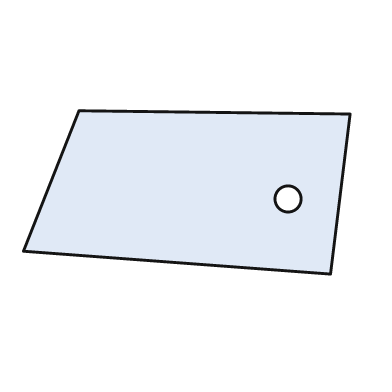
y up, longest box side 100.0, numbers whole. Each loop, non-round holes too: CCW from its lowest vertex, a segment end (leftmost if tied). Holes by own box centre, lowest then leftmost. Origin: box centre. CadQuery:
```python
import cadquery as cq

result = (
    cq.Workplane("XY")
    .moveTo(44.0, -25.0)
    .lineTo(50.0, 24.0)
    .lineTo(-33.0, 25.0)
    .lineTo(-50.0, -18.0)
    .close()
    .moveTo(31.0, -2.0)
    .circle(4.0)
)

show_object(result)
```